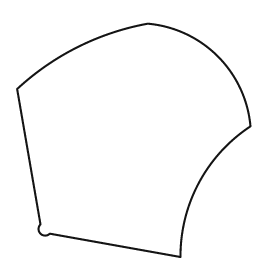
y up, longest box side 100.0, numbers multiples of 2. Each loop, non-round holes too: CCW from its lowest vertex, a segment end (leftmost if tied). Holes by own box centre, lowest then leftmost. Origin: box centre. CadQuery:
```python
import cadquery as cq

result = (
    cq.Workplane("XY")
    .moveTo(20.0, -50.0)
    .threePointArc((28.0, -18.0), (50.0, 6.0))
    .threePointArc((36.0, 36.0), (6.0, 50.0))
    .threePointArc((-24.0, 40.0), (-50.0, 22.0))
    .lineTo(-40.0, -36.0)
    .threePointArc((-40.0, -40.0), (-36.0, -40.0))
    .close()
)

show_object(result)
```